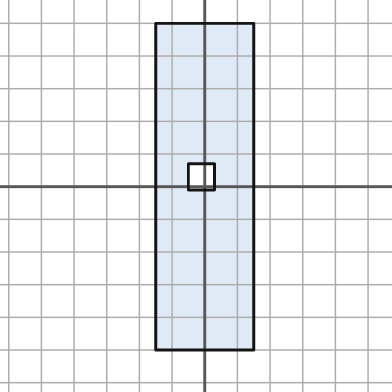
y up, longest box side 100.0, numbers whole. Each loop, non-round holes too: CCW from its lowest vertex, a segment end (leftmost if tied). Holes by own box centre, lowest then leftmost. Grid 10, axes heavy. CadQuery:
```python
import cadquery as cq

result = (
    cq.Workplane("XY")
    .moveTo(-15.0, -50.0)
    .lineTo(15.0, -50.0)
    .lineTo(15.0, 50.0)
    .lineTo(-15.0, 50.0)
    .close()
    .moveTo(-5.0, -1.0)
    .lineTo(3.0, -1.0)
    .lineTo(3.0, 7.0)
    .lineTo(-5.0, 7.0)
    .close()
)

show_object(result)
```